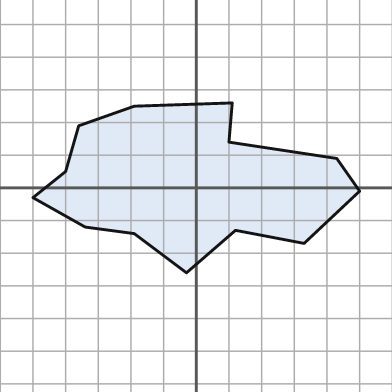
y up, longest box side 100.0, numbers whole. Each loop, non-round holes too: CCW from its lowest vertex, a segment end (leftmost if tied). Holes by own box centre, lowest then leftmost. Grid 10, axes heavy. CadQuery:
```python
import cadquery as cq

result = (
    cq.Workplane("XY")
    .moveTo(-3.0, -26.0)
    .lineTo(12.0, -13.0)
    .lineTo(33.0, -17.0)
    .lineTo(50.0, -1.0)
    .lineTo(43.0, 9.0)
    .lineTo(10.0, 14.0)
    .lineTo(11.0, 26.0)
    .lineTo(-19.0, 25.0)
    .lineTo(-36.0, 19.0)
    .lineTo(-40.0, 5.0)
    .lineTo(-50.0, -3.0)
    .lineTo(-34.0, -12.0)
    .lineTo(-19.0, -14.0)
    .close()
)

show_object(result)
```